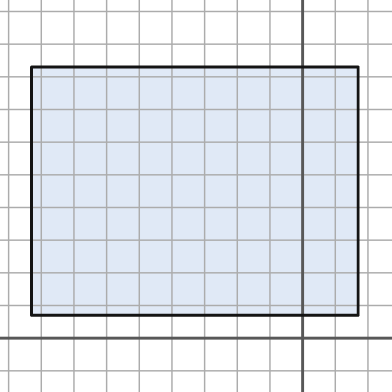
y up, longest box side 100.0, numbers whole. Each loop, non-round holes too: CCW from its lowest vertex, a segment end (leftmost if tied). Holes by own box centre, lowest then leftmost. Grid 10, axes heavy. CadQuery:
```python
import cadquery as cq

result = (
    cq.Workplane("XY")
    .moveTo(-83.0, 7.0)
    .lineTo(17.0, 7.0)
    .lineTo(17.0, 83.0)
    .lineTo(-83.0, 83.0)
    .close()
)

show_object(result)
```